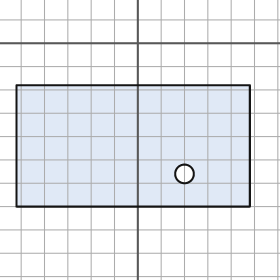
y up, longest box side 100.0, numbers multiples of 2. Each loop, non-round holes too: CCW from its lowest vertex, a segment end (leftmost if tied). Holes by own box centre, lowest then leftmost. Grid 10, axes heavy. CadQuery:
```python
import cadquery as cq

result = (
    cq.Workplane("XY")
    .moveTo(-52.0, -70.0)
    .lineTo(48.0, -70.0)
    .lineTo(48.0, -18.0)
    .lineTo(-52.0, -18.0)
    .close()
    .moveTo(20.0, -56.0)
    .circle(4.0)
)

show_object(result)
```